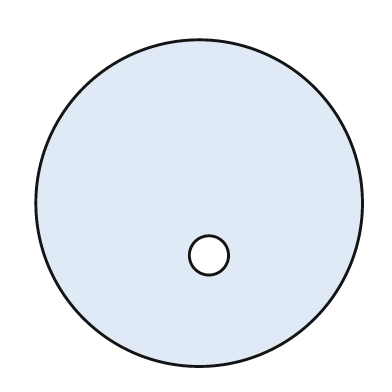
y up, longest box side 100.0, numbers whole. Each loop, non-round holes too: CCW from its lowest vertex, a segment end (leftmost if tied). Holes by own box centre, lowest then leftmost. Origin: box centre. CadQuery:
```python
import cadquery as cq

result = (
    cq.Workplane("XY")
    .moveTo(0.0, 0.0)
    .circle(50.0)
    .moveTo(3.0, -16.0)
    .circle(6.0)
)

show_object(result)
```